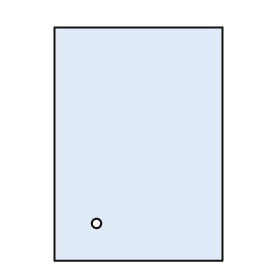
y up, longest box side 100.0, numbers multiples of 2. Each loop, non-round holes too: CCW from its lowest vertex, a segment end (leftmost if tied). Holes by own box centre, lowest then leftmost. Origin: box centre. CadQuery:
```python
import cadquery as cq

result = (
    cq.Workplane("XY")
    .moveTo(-36.0, -50.0)
    .lineTo(36.0, -50.0)
    .lineTo(36.0, 50.0)
    .lineTo(-36.0, 50.0)
    .close()
    .moveTo(-18.0, -34.0)
    .circle(2.0)
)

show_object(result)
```